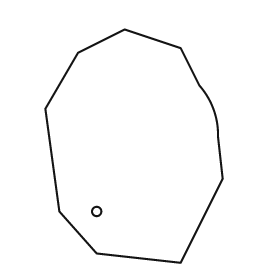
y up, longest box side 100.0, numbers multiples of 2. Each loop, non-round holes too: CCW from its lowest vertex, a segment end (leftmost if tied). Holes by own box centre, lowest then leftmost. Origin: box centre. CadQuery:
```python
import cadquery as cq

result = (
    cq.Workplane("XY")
    .moveTo(20.0, -50.0)
    .lineTo(38.0, -14.0)
    .lineTo(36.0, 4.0)
    .threePointArc((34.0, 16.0), (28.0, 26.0))
    .lineTo(20.0, 42.0)
    .lineTo(-4.0, 50.0)
    .lineTo(-24.0, 40.0)
    .lineTo(-38.0, 16.0)
    .lineTo(-32.0, -28.0)
    .lineTo(-16.0, -46.0)
    .close()
    .moveTo(-16.0, -28.0)
    .circle(2.0)
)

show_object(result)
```